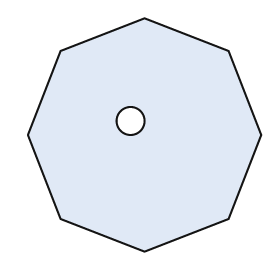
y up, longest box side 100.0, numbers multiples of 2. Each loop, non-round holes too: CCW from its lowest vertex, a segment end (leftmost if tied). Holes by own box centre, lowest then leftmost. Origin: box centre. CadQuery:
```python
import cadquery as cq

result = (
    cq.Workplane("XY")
    .moveTo(0.0, -50.0)
    .lineTo(36.0, -36.0)
    .lineTo(50.0, 0.0)
    .lineTo(36.0, 36.0)
    .lineTo(0.0, 50.0)
    .lineTo(-36.0, 36.0)
    .lineTo(-50.0, 0.0)
    .lineTo(-36.0, -36.0)
    .close()
    .moveTo(-6.0, 6.0)
    .circle(6.0)
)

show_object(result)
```